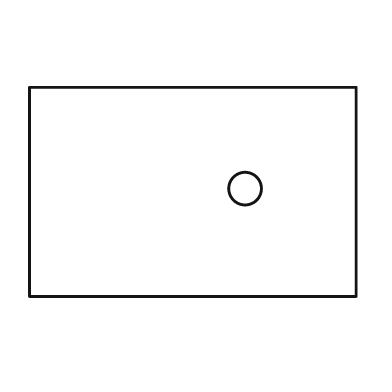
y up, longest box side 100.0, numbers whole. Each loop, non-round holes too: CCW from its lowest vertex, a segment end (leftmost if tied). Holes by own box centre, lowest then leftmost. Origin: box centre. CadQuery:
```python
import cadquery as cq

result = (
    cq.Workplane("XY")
    .moveTo(-50.0, -32.0)
    .lineTo(50.0, -32.0)
    .lineTo(50.0, 32.0)
    .lineTo(-50.0, 32.0)
    .close()
    .moveTo(16.0, 1.0)
    .circle(5.0)
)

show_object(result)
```